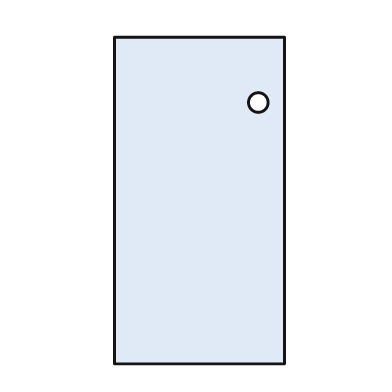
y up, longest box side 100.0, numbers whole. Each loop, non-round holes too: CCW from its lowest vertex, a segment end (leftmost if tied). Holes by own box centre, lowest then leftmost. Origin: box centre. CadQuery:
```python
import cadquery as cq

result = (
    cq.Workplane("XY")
    .moveTo(-26.0, -50.0)
    .lineTo(26.0, -50.0)
    .lineTo(26.0, 50.0)
    .lineTo(-26.0, 50.0)
    .close()
    .moveTo(18.0, 30.0)
    .circle(3.0)
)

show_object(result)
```